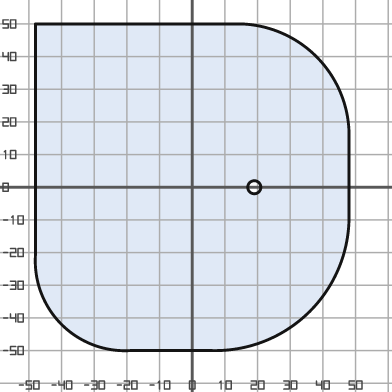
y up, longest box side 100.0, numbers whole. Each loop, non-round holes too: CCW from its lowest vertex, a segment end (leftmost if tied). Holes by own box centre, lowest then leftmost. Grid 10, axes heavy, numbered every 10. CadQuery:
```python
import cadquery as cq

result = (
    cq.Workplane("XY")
    .moveTo(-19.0, -50.0)
    .lineTo(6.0, -50.0)
    .threePointArc((36.0, -38.0), (48.0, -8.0))
    .lineTo(48.0, 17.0)
    .threePointArc((38.0, 40.0), (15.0, 50.0))
    .lineTo(-48.0, 50.0)
    .lineTo(-48.0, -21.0)
    .threePointArc((-40.0, -42.0), (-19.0, -50.0))
    .close()
    .moveTo(19.0, 0.0)
    .circle(2.0)
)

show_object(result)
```